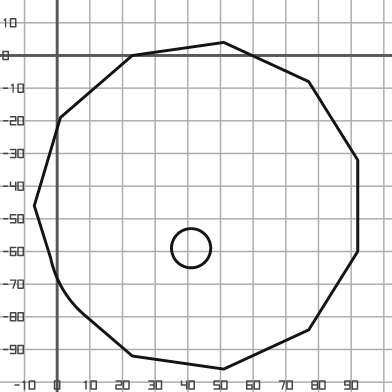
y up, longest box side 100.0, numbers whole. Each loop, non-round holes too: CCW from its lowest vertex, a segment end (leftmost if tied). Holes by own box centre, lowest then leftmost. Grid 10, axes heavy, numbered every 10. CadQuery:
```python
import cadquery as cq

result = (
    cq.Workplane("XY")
    .moveTo(51.0, -96.0)
    .lineTo(77.0, -84.0)
    .lineTo(92.0, -60.0)
    .lineTo(92.0, -32.0)
    .lineTo(77.0, -8.0)
    .lineTo(51.0, 4.0)
    .lineTo(23.0, 0.0)
    .lineTo(1.0, -19.0)
    .lineTo(-7.0, -46.0)
    .lineTo(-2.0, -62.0)
    .threePointArc((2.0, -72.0), (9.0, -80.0))
    .lineTo(23.0, -92.0)
    .close()
    .moveTo(41.0, -59.0)
    .circle(6.0)
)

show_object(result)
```